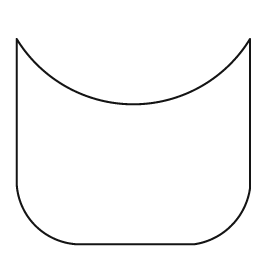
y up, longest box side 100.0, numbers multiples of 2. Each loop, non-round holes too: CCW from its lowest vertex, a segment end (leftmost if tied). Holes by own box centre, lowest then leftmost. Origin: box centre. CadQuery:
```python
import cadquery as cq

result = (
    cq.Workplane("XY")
    .moveTo(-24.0, -44.0)
    .lineTo(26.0, -44.0)
    .threePointArc((42.0, -36.0), (50.0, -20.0))
    .lineTo(50.0, 44.0)
    .threePointArc((0.0, 16.0), (-50.0, 44.0))
    .lineTo(-50.0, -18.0)
    .threePointArc((-42.0, -36.0), (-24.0, -44.0))
    .close()
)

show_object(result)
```